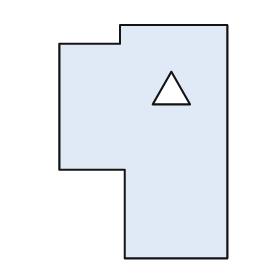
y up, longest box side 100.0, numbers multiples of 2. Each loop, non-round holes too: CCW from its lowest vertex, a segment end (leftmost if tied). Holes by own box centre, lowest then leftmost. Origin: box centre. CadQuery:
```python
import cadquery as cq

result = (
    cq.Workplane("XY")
    .moveTo(-8.0, -50.0)
    .lineTo(36.0, -50.0)
    .lineTo(36.0, 50.0)
    .lineTo(-10.0, 50.0)
    .lineTo(-10.0, 42.0)
    .lineTo(-36.0, 42.0)
    .lineTo(-36.0, -12.0)
    .lineTo(-8.0, -12.0)
    .close()
    .moveTo(4.0, 16.0)
    .lineTo(20.0, 16.0)
    .lineTo(12.0, 30.0)
    .close()
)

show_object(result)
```